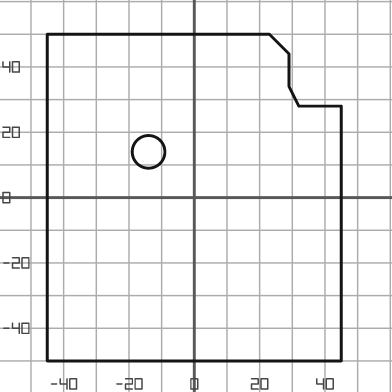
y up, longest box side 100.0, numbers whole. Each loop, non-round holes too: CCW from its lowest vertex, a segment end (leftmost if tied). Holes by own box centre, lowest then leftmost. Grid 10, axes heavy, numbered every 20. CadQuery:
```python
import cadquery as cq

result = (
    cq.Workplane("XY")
    .moveTo(-45.0, -50.0)
    .lineTo(45.0, -50.0)
    .lineTo(45.0, 28.0)
    .lineTo(32.0, 28.0)
    .lineTo(29.0, 34.0)
    .lineTo(29.0, 44.0)
    .lineTo(23.0, 50.0)
    .lineTo(-45.0, 50.0)
    .close()
    .moveTo(-14.0, 14.0)
    .circle(5.0)
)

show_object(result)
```